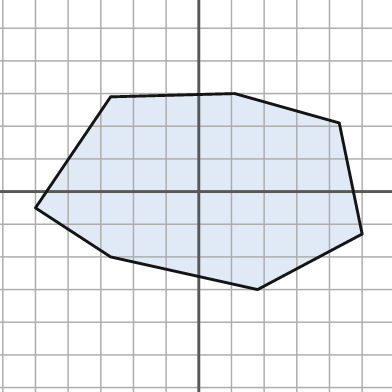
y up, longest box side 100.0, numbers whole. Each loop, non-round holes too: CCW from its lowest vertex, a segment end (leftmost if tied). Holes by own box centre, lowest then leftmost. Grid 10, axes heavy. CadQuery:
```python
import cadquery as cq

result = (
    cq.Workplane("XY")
    .moveTo(18.0, -30.0)
    .lineTo(50.0, -13.0)
    .lineTo(43.0, 21.0)
    .lineTo(11.0, 30.0)
    .lineTo(-27.0, 29.0)
    .lineTo(-50.0, -5.0)
    .lineTo(-27.0, -20.0)
    .close()
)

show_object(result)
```